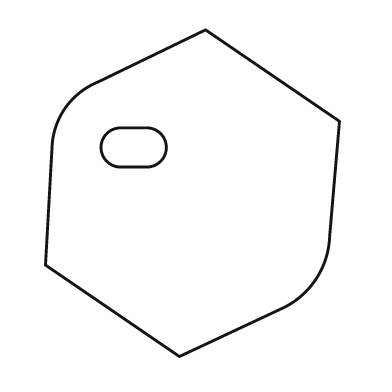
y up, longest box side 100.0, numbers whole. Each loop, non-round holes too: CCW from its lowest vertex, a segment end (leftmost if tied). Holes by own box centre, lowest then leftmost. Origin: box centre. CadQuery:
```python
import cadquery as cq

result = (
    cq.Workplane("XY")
    .moveTo(-4.0, -50.0)
    .lineTo(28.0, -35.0)
    .threePointArc((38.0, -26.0), (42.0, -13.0))
    .lineTo(45.0, 22.0)
    .lineTo(4.0, 50.0)
    .lineTo(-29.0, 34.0)
    .threePointArc((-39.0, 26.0), (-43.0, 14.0))
    .lineTo(-45.0, -22.0)
    .close()
    .moveTo(-22.0, 8.0)
    .lineTo(-14.0, 8.0)
    .threePointArc((-8.0, 14.0), (-14.0, 20.0))
    .lineTo(-22.0, 20.0)
    .threePointArc((-28.0, 14.0), (-22.0, 8.0))
    .close()
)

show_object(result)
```